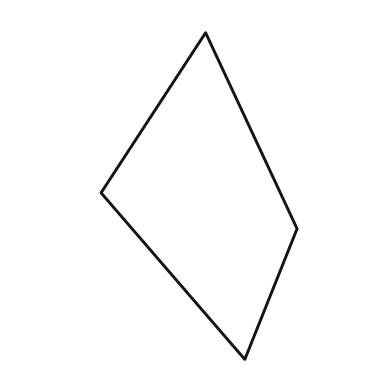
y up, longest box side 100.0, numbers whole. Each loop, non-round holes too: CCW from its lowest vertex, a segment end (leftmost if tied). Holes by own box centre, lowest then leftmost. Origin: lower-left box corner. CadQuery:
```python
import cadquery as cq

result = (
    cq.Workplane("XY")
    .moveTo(44.0, 0.0)
    .lineTo(60.0, 40.0)
    .lineTo(32.0, 100.0)
    .lineTo(0.0, 51.0)
    .close()
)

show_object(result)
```